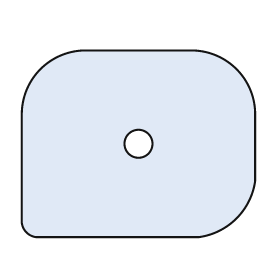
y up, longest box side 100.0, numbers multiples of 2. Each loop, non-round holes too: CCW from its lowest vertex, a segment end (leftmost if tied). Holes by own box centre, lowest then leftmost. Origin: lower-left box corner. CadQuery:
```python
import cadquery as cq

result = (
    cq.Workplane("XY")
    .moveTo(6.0, 0.0)
    .lineTo(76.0, 0.0)
    .threePointArc((92.0, 8.0), (100.0, 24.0))
    .lineTo(100.0, 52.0)
    .threePointArc((92.0, 72.0), (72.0, 80.0))
    .lineTo(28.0, 80.0)
    .threePointArc((8.0, 72.0), (0.0, 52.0))
    .lineTo(0.0, 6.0)
    .threePointArc((2.0, 2.0), (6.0, 0.0))
    .close()
    .moveTo(50.0, 40.0)
    .circle(6.0)
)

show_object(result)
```